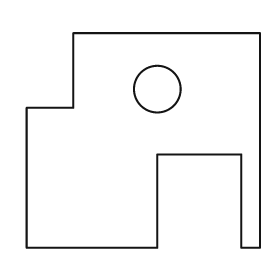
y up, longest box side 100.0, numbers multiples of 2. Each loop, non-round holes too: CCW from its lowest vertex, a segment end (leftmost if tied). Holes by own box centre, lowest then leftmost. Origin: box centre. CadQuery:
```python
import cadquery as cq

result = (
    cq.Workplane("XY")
    .moveTo(-50.0, -46.0)
    .lineTo(6.0, -46.0)
    .lineTo(6.0, -6.0)
    .lineTo(42.0, -6.0)
    .lineTo(42.0, -46.0)
    .lineTo(50.0, -46.0)
    .lineTo(50.0, 46.0)
    .lineTo(-30.0, 46.0)
    .lineTo(-30.0, 14.0)
    .lineTo(-50.0, 14.0)
    .close()
    .moveTo(6.0, 22.0)
    .circle(10.0)
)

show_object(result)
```